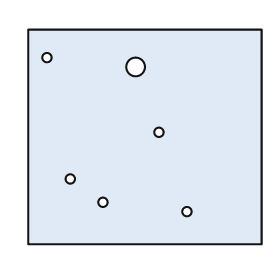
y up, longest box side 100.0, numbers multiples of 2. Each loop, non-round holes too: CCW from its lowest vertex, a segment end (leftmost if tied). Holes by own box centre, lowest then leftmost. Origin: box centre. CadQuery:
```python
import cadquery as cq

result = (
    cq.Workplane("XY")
    .moveTo(-50.0, -46.0)
    .lineTo(50.0, -46.0)
    .lineTo(50.0, 46.0)
    .lineTo(-50.0, 46.0)
    .close()
    .moveTo(18.0, -32.0)
    .circle(2.0)
    .moveTo(-18.0, -28.0)
    .circle(2.0)
    .moveTo(-32.0, -18.0)
    .circle(2.0)
    .moveTo(6.0, 2.0)
    .circle(2.0)
    .moveTo(-4.0, 30.0)
    .circle(4.0)
    .moveTo(-42.0, 34.0)
    .circle(2.0)
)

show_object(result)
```